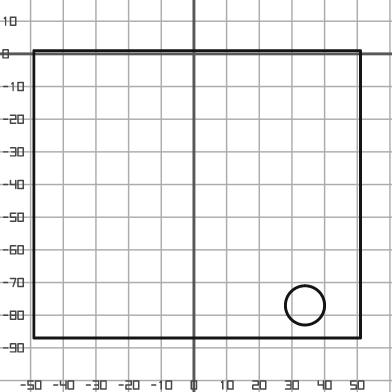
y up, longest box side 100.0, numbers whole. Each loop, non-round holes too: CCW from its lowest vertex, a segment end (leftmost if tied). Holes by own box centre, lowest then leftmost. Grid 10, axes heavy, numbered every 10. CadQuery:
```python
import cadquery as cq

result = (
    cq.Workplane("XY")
    .moveTo(-49.0, -87.0)
    .lineTo(51.0, -87.0)
    .lineTo(51.0, 1.0)
    .lineTo(-49.0, 1.0)
    .close()
    .moveTo(34.0, -77.0)
    .circle(6.0)
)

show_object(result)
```